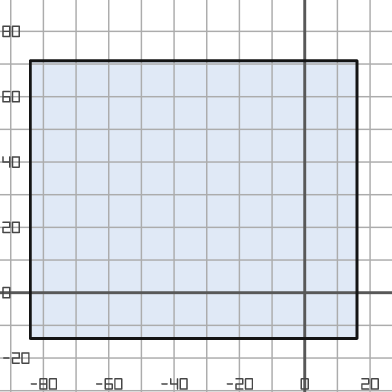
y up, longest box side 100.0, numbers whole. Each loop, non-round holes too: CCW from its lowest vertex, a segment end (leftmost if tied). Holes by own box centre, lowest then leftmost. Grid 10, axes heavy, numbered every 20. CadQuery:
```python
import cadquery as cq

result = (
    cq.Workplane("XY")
    .moveTo(-84.0, -14.0)
    .lineTo(16.0, -14.0)
    .lineTo(16.0, 71.0)
    .lineTo(-84.0, 71.0)
    .close()
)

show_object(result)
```